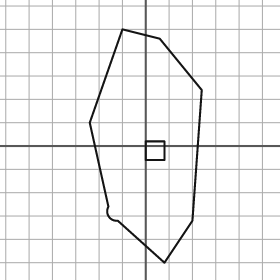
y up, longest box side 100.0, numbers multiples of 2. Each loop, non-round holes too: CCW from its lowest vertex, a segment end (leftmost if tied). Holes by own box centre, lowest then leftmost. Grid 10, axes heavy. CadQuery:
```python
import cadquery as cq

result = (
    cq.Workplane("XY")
    .moveTo(8.0, -50.0)
    .lineTo(20.0, -32.0)
    .lineTo(24.0, 24.0)
    .lineTo(6.0, 46.0)
    .lineTo(-10.0, 50.0)
    .lineTo(-24.0, 10.0)
    .lineTo(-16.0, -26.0)
    .threePointArc((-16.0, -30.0), (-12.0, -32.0))
    .close()
    .moveTo(0.0, -6.0)
    .lineTo(8.0, -6.0)
    .lineTo(8.0, 2.0)
    .lineTo(0.0, 2.0)
    .close()
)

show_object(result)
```